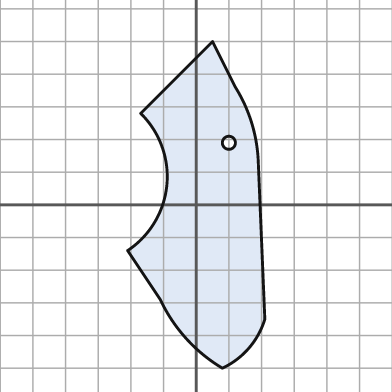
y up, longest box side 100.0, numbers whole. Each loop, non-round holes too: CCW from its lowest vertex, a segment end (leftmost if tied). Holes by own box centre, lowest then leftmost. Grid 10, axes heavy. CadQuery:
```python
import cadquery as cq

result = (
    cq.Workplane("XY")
    .moveTo(8.0, -50.0)
    .threePointArc((16.0, -44.0), (21.0, -35.0))
    .lineTo(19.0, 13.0)
    .threePointArc((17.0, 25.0), (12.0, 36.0))
    .lineTo(5.0, 50.0)
    .lineTo(-17.0, 28.0)
    .threePointArc((-9.0, 6.0), (-21.0, -14.0))
    .lineTo(-11.0, -29.0)
    .threePointArc((-3.0, -41.0), (8.0, -50.0))
    .close()
    .moveTo(10.0, 19.0)
    .circle(2.0)
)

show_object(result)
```